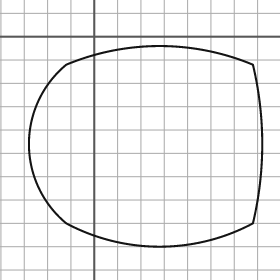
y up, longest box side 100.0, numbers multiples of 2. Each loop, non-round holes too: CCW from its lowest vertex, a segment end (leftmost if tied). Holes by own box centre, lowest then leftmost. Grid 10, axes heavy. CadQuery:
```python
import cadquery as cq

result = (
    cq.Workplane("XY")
    .moveTo(-12.0, -80.0)
    .threePointArc((28.0, -90.0), (68.0, -80.0))
    .threePointArc((72.0, -46.0), (68.0, -12.0))
    .threePointArc((28.0, -4.0), (-12.0, -12.0))
    .threePointArc((-28.0, -46.0), (-12.0, -80.0))
    .close()
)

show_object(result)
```